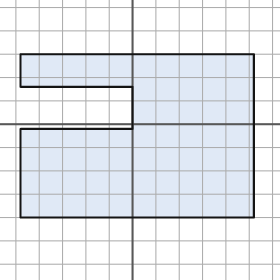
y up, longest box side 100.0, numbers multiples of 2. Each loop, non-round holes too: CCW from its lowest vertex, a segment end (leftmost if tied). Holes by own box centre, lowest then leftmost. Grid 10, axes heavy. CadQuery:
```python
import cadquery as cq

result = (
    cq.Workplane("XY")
    .moveTo(-48.0, -40.0)
    .lineTo(52.0, -40.0)
    .lineTo(52.0, 30.0)
    .lineTo(-48.0, 30.0)
    .lineTo(-48.0, 16.0)
    .lineTo(0.0, 16.0)
    .lineTo(0.0, -2.0)
    .lineTo(-48.0, -2.0)
    .close()
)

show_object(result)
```